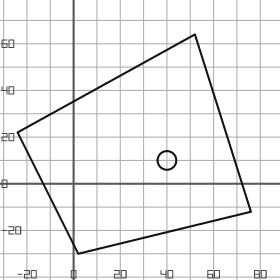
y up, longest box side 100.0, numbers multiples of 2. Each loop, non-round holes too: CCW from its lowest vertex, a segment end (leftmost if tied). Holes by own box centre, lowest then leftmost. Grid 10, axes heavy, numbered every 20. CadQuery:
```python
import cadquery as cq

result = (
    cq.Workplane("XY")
    .moveTo(2.0, -30.0)
    .lineTo(76.0, -12.0)
    .lineTo(52.0, 64.0)
    .lineTo(-24.0, 22.0)
    .close()
    .moveTo(40.0, 10.0)
    .circle(4.0)
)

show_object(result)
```